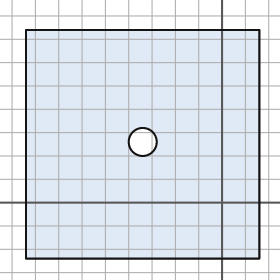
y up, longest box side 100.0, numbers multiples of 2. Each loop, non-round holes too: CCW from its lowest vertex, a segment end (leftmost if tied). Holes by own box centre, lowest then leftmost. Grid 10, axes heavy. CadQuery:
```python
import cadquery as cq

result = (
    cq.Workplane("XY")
    .moveTo(-84.0, -24.0)
    .lineTo(16.0, -24.0)
    .lineTo(16.0, 74.0)
    .lineTo(-84.0, 74.0)
    .close()
    .moveTo(-34.0, 26.0)
    .circle(6.0)
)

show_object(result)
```